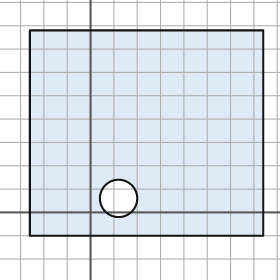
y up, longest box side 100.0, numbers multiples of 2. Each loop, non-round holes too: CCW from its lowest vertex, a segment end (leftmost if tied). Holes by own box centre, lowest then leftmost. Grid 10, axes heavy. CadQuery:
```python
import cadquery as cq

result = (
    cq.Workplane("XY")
    .moveTo(-26.0, -10.0)
    .lineTo(74.0, -10.0)
    .lineTo(74.0, 78.0)
    .lineTo(-26.0, 78.0)
    .close()
    .moveTo(12.0, 6.0)
    .circle(8.0)
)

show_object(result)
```